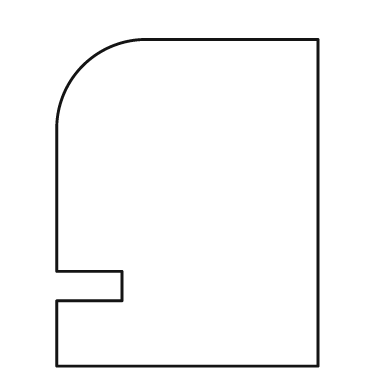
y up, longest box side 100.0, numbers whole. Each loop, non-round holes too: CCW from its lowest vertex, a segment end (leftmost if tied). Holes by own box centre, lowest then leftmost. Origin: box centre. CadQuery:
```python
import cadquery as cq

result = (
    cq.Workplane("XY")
    .moveTo(-40.0, -50.0)
    .lineTo(40.0, -50.0)
    .lineTo(40.0, 50.0)
    .lineTo(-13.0, 50.0)
    .threePointArc((-32.0, 42.0), (-40.0, 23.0))
    .lineTo(-40.0, -21.0)
    .lineTo(-20.0, -21.0)
    .lineTo(-20.0, -30.0)
    .lineTo(-40.0, -30.0)
    .close()
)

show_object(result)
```